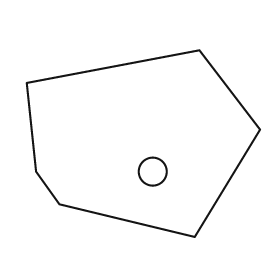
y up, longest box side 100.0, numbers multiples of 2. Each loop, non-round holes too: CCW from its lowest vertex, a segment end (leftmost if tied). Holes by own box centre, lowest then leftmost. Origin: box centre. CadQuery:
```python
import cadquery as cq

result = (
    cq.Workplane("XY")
    .moveTo(22.0, -40.0)
    .lineTo(50.0, 6.0)
    .lineTo(24.0, 40.0)
    .lineTo(-50.0, 26.0)
    .lineTo(-46.0, -12.0)
    .lineTo(-36.0, -26.0)
    .close()
    .moveTo(4.0, -12.0)
    .circle(6.0)
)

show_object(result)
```